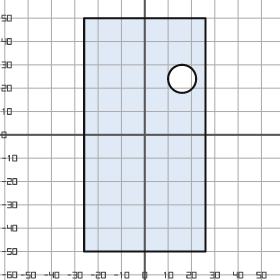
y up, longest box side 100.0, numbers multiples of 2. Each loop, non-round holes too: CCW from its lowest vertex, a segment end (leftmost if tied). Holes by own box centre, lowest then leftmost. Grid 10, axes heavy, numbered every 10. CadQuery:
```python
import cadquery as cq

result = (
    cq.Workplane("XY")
    .moveTo(-26.0, -50.0)
    .lineTo(26.0, -50.0)
    .lineTo(26.0, 50.0)
    .lineTo(-26.0, 50.0)
    .close()
    .moveTo(16.0, 24.0)
    .circle(6.0)
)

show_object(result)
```